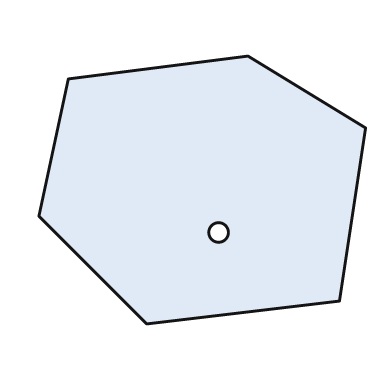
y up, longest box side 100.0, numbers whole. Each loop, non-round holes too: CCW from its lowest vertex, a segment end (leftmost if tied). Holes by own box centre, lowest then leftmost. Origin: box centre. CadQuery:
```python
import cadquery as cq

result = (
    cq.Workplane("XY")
    .moveTo(-17.0, -41.0)
    .lineTo(42.0, -34.0)
    .lineTo(50.0, 19.0)
    .lineTo(14.0, 41.0)
    .lineTo(-41.0, 34.0)
    .lineTo(-50.0, -8.0)
    .close()
    .moveTo(5.0, -13.0)
    .circle(3.0)
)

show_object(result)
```